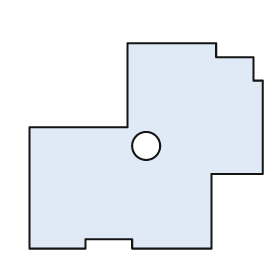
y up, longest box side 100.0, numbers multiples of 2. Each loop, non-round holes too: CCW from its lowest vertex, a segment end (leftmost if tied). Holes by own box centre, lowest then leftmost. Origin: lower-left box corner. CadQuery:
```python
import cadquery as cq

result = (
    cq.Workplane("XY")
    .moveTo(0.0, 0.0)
    .lineTo(24.0, 0.0)
    .lineTo(24.0, 4.0)
    .lineTo(44.0, 4.0)
    .lineTo(44.0, 0.0)
    .lineTo(78.0, 0.0)
    .lineTo(78.0, 32.0)
    .lineTo(100.0, 32.0)
    .lineTo(100.0, 72.0)
    .lineTo(96.0, 72.0)
    .lineTo(96.0, 82.0)
    .lineTo(80.0, 82.0)
    .lineTo(80.0, 88.0)
    .lineTo(42.0, 88.0)
    .lineTo(42.0, 52.0)
    .lineTo(0.0, 52.0)
    .close()
    .moveTo(50.0, 44.0)
    .circle(6.0)
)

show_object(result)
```